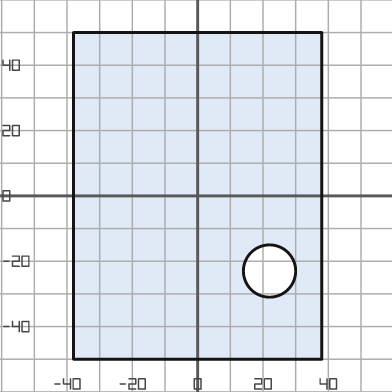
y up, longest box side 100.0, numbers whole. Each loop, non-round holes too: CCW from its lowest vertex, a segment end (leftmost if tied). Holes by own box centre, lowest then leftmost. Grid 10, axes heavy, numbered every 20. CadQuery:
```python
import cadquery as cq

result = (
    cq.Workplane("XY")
    .moveTo(-38.0, -50.0)
    .lineTo(38.0, -50.0)
    .lineTo(38.0, 50.0)
    .lineTo(-38.0, 50.0)
    .close()
    .moveTo(22.0, -23.0)
    .circle(8.0)
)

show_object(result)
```